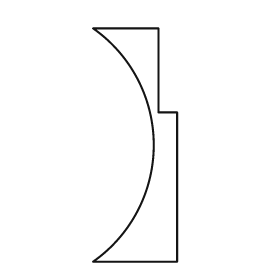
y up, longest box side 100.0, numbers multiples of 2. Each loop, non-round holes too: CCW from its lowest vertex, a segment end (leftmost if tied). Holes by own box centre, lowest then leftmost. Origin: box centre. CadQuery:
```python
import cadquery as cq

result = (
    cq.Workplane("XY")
    .moveTo(-18.0, -50.0)
    .lineTo(18.0, -50.0)
    .lineTo(18.0, 14.0)
    .lineTo(10.0, 14.0)
    .lineTo(10.0, 50.0)
    .lineTo(-18.0, 50.0)
    .threePointArc((8.0, 0.0), (-18.0, -50.0))
    .close()
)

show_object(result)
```